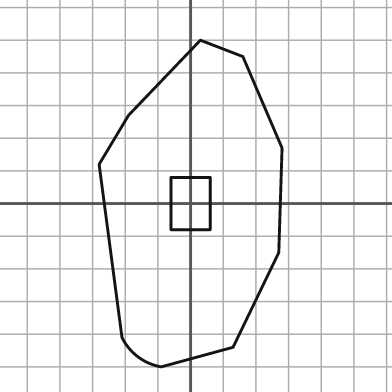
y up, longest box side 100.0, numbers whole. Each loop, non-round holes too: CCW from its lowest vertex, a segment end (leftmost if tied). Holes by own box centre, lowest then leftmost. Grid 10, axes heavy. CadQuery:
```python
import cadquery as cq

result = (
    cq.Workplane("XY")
    .moveTo(-9.0, -50.0)
    .lineTo(13.0, -44.0)
    .lineTo(27.0, -15.0)
    .lineTo(28.0, 17.0)
    .lineTo(16.0, 45.0)
    .lineTo(3.0, 50.0)
    .lineTo(-19.0, 27.0)
    .lineTo(-28.0, 12.0)
    .lineTo(-21.0, -41.0)
    .threePointArc((-16.0, -47.0), (-9.0, -50.0))
    .close()
    .moveTo(-6.0, -8.0)
    .lineTo(6.0, -8.0)
    .lineTo(6.0, 8.0)
    .lineTo(-6.0, 8.0)
    .close()
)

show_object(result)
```